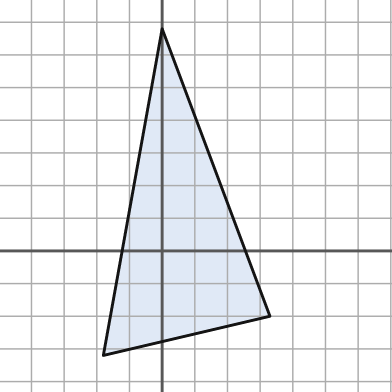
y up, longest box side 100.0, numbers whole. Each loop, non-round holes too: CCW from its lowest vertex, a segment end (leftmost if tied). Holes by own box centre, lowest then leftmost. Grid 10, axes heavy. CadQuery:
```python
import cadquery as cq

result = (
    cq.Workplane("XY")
    .moveTo(-18.0, -32.0)
    .lineTo(33.0, -20.0)
    .lineTo(0.0, 68.0)
    .close()
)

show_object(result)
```